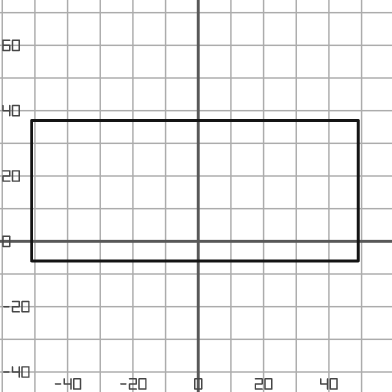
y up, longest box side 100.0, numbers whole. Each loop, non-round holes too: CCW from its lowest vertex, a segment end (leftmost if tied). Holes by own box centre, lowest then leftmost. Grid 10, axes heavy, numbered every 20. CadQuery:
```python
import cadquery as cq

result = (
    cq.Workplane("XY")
    .moveTo(-51.0, -6.0)
    .lineTo(49.0, -6.0)
    .lineTo(49.0, 37.0)
    .lineTo(-51.0, 37.0)
    .close()
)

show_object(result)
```